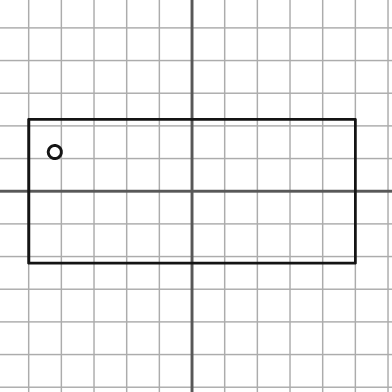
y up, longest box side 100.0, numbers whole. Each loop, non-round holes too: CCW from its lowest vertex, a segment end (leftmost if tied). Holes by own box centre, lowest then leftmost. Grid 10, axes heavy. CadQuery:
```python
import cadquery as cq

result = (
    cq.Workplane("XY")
    .moveTo(-50.0, -22.0)
    .lineTo(50.0, -22.0)
    .lineTo(50.0, 22.0)
    .lineTo(-50.0, 22.0)
    .close()
    .moveTo(-42.0, 12.0)
    .circle(2.0)
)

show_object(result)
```